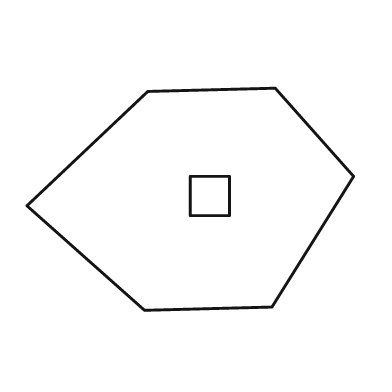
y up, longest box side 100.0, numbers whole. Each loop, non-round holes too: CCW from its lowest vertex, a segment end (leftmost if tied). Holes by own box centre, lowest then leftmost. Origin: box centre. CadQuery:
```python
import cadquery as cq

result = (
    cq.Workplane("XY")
    .moveTo(-14.0, -34.0)
    .lineTo(25.0, -33.0)
    .lineTo(50.0, 7.0)
    .lineTo(26.0, 34.0)
    .lineTo(-13.0, 33.0)
    .lineTo(-50.0, -2.0)
    .close()
    .moveTo(0.0, -5.0)
    .lineTo(12.0, -5.0)
    .lineTo(12.0, 7.0)
    .lineTo(0.0, 7.0)
    .close()
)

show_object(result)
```